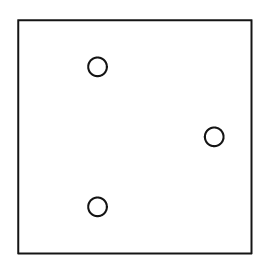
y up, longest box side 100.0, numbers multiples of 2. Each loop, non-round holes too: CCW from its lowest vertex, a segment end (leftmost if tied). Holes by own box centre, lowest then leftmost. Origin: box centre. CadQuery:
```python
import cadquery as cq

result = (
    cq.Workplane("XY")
    .moveTo(-50.0, -50.0)
    .lineTo(50.0, -50.0)
    .lineTo(50.0, 50.0)
    .lineTo(-50.0, 50.0)
    .close()
    .moveTo(-16.0, -30.0)
    .circle(4.0)
    .moveTo(34.0, 0.0)
    .circle(4.0)
    .moveTo(-16.0, 30.0)
    .circle(4.0)
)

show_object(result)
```